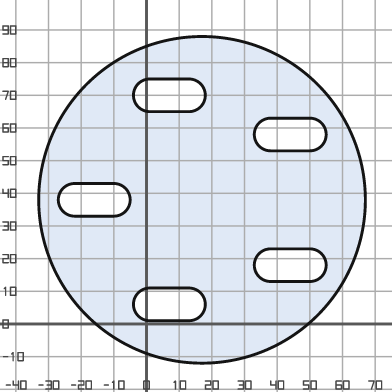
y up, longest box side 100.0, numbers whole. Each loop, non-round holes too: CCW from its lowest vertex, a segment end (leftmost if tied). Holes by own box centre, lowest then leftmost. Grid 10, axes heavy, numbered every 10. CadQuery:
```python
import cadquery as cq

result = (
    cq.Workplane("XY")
    .moveTo(17.0, 38.0)
    .circle(50.0)
    .moveTo(1.0, 1.0)
    .lineTo(13.0, 1.0)
    .threePointArc((18.0, 6.0), (13.0, 11.0))
    .lineTo(1.0, 11.0)
    .threePointArc((-4.0, 6.0), (1.0, 1.0))
    .close()
    .moveTo(38.0, 13.0)
    .lineTo(50.0, 13.0)
    .threePointArc((55.0, 18.0), (50.0, 23.0))
    .lineTo(38.0, 23.0)
    .threePointArc((33.0, 18.0), (38.0, 13.0))
    .close()
    .moveTo(-22.0, 33.0)
    .lineTo(-10.0, 33.0)
    .threePointArc((-5.0, 38.0), (-10.0, 43.0))
    .lineTo(-22.0, 43.0)
    .threePointArc((-27.0, 38.0), (-22.0, 33.0))
    .close()
    .moveTo(38.0, 53.0)
    .lineTo(50.0, 53.0)
    .threePointArc((55.0, 58.0), (50.0, 63.0))
    .lineTo(38.0, 63.0)
    .threePointArc((33.0, 58.0), (38.0, 53.0))
    .close()
    .moveTo(1.0, 65.0)
    .lineTo(13.0, 65.0)
    .threePointArc((18.0, 70.0), (13.0, 75.0))
    .lineTo(1.0, 75.0)
    .threePointArc((-4.0, 70.0), (1.0, 65.0))
    .close()
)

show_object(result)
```